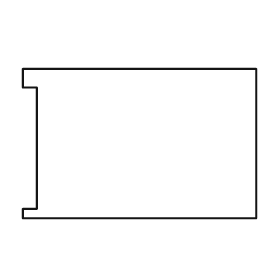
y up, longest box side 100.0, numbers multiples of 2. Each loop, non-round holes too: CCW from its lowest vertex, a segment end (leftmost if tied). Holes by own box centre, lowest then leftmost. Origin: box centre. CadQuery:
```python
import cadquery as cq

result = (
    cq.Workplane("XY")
    .moveTo(-50.0, -32.0)
    .lineTo(50.0, -32.0)
    .lineTo(50.0, 32.0)
    .lineTo(-50.0, 32.0)
    .lineTo(-50.0, 24.0)
    .lineTo(-44.0, 24.0)
    .lineTo(-44.0, -28.0)
    .lineTo(-50.0, -28.0)
    .close()
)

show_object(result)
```